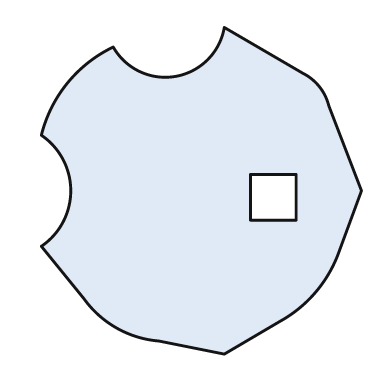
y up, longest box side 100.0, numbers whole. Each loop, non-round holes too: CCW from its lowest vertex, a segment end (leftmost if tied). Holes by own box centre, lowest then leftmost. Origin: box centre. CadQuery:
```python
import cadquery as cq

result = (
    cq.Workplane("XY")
    .moveTo(7.0, -50.0)
    .lineTo(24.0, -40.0)
    .threePointArc((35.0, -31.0), (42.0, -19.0))
    .lineTo(49.0, 0.0)
    .lineTo(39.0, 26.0)
    .threePointArc((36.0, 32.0), (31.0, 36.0))
    .lineTo(7.0, 50.0)
    .threePointArc((-8.0, 35.0), (-27.0, 44.0))
    .threePointArc((-41.0, 33.0), (-49.0, 17.0))
    .threePointArc((-40.0, 0.0), (-49.0, -17.0))
    .lineTo(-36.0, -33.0)
    .threePointArc((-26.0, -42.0), (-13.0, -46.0))
    .close()
    .moveTo(15.0, -9.0)
    .lineTo(29.0, -9.0)
    .lineTo(29.0, 5.0)
    .lineTo(15.0, 5.0)
    .close()
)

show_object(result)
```